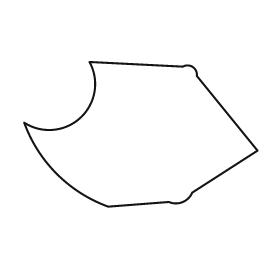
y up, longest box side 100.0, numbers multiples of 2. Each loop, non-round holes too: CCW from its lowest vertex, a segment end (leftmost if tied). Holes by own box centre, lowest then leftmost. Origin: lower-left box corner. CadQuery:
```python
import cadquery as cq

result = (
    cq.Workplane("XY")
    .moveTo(36.0, 0.0)
    .lineTo(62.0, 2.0)
    .threePointArc((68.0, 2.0), (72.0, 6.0))
    .lineTo(100.0, 24.0)
    .lineTo(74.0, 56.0)
    .threePointArc((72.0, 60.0), (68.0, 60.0))
    .lineTo(28.0, 62.0)
    .threePointArc((24.0, 38.0), (0.0, 36.0))
    .threePointArc((14.0, 14.0), (36.0, 0.0))
    .close()
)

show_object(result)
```